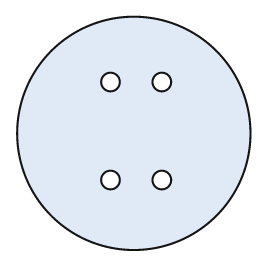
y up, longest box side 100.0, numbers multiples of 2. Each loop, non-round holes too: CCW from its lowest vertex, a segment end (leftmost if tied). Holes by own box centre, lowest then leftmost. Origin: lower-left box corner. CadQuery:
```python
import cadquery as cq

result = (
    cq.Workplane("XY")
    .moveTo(50.0, 50.0)
    .circle(50.0)
    .moveTo(40.0, 30.0)
    .circle(4.0)
    .moveTo(62.0, 30.0)
    .circle(4.0)
    .moveTo(40.0, 72.0)
    .circle(4.0)
    .moveTo(62.0, 72.0)
    .circle(4.0)
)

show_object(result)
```